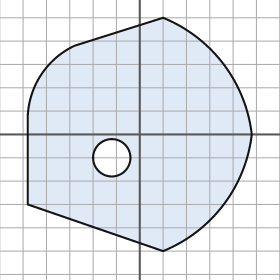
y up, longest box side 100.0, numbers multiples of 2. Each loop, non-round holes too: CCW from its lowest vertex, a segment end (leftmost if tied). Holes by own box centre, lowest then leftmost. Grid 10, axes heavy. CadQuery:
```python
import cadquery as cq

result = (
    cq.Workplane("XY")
    .moveTo(10.0, -50.0)
    .threePointArc((36.0, -30.0), (48.0, 0.0))
    .threePointArc((36.0, 30.0), (10.0, 50.0))
    .lineTo(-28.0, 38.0)
    .threePointArc((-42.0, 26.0), (-48.0, 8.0))
    .lineTo(-48.0, -30.0)
    .close()
    .moveTo(-12.0, -10.0)
    .circle(8.0)
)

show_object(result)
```